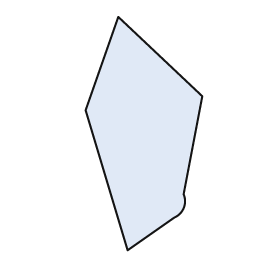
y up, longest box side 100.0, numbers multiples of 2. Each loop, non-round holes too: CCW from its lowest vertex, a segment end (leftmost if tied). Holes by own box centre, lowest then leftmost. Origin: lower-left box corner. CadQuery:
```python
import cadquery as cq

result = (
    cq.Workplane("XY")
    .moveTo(18.0, 0.0)
    .lineTo(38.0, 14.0)
    .threePointArc((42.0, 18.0), (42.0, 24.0))
    .lineTo(50.0, 66.0)
    .lineTo(14.0, 100.0)
    .lineTo(0.0, 60.0)
    .close()
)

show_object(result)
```